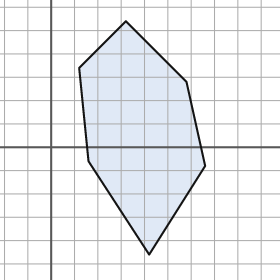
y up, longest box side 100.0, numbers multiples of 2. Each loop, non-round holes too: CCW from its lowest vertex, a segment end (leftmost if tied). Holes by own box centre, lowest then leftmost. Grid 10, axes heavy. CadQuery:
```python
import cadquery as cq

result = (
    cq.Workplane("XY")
    .moveTo(42.0, -46.0)
    .lineTo(66.0, -8.0)
    .lineTo(58.0, 28.0)
    .lineTo(32.0, 54.0)
    .lineTo(12.0, 34.0)
    .lineTo(16.0, -6.0)
    .close()
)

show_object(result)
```